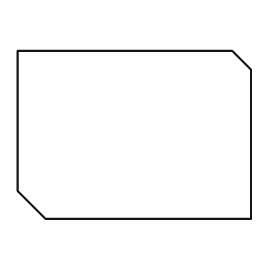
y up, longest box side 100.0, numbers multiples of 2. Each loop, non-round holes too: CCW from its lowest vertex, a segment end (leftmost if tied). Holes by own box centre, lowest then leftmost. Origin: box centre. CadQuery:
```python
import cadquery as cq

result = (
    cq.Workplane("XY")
    .moveTo(-38.0, -36.0)
    .lineTo(50.0, -36.0)
    .lineTo(50.0, 28.0)
    .lineTo(42.0, 36.0)
    .lineTo(-50.0, 36.0)
    .lineTo(-50.0, -24.0)
    .close()
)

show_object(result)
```